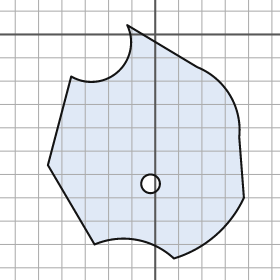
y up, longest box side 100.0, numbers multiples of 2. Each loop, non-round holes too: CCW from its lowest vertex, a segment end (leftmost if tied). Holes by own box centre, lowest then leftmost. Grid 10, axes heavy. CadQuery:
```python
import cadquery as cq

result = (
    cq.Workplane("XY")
    .moveTo(8.0, -96.0)
    .threePointArc((26.0, -86.0), (38.0, -70.0))
    .lineTo(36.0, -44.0)
    .threePointArc((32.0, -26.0), (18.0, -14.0))
    .lineTo(-12.0, 4.0)
    .threePointArc((-16.0, -16.0), (-36.0, -18.0))
    .lineTo(-46.0, -56.0)
    .lineTo(-26.0, -90.0)
    .threePointArc((-8.0, -88.0), (8.0, -96.0))
    .close()
    .moveTo(-2.0, -64.0)
    .circle(4.0)
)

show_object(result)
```